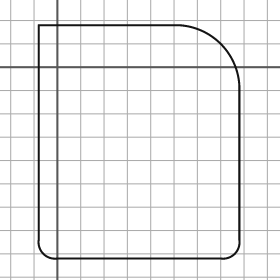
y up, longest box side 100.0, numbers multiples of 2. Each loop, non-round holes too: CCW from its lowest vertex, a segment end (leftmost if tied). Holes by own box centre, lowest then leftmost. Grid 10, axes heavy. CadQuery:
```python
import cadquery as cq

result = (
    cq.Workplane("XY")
    .moveTo(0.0, -82.0)
    .lineTo(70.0, -82.0)
    .threePointArc((76.0, -80.0), (78.0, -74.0))
    .lineTo(78.0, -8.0)
    .threePointArc((70.0, 10.0), (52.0, 18.0))
    .lineTo(-8.0, 18.0)
    .lineTo(-8.0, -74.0)
    .threePointArc((-6.0, -80.0), (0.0, -82.0))
    .close()
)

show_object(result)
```